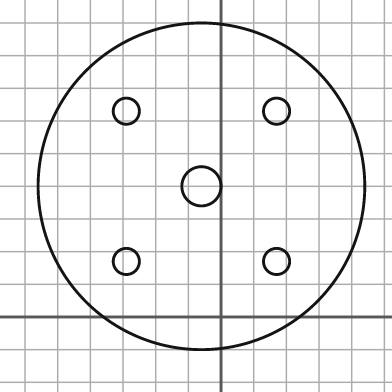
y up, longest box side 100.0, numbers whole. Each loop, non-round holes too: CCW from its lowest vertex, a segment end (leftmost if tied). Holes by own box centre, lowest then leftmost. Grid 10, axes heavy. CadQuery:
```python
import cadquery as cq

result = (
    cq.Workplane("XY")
    .moveTo(-6.0, 40.0)
    .circle(50.0)
    .moveTo(-29.0, 17.0)
    .circle(4.0)
    .moveTo(17.0, 17.0)
    .circle(4.0)
    .moveTo(-6.0, 40.0)
    .circle(6.0)
    .moveTo(-29.0, 63.0)
    .circle(4.0)
    .moveTo(17.0, 63.0)
    .circle(4.0)
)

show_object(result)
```